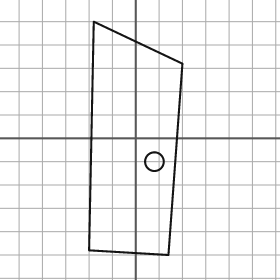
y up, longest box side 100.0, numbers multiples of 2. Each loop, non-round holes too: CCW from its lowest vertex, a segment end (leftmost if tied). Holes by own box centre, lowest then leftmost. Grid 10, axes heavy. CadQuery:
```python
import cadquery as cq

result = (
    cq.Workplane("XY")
    .moveTo(14.0, -50.0)
    .lineTo(20.0, 32.0)
    .lineTo(-18.0, 50.0)
    .lineTo(-20.0, -48.0)
    .close()
    .moveTo(8.0, -10.0)
    .circle(4.0)
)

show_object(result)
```